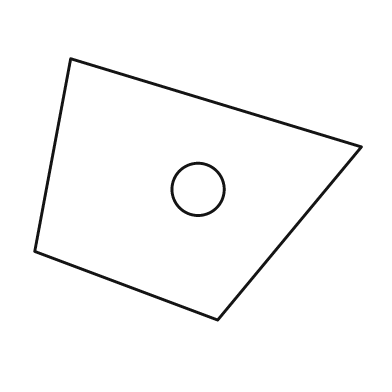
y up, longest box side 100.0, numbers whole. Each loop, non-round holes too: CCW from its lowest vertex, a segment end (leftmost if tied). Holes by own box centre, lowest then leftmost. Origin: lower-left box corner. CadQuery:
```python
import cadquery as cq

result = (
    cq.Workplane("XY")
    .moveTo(56.0, 0.0)
    .lineTo(100.0, 53.0)
    .lineTo(11.0, 80.0)
    .lineTo(0.0, 21.0)
    .close()
    .moveTo(50.0, 40.0)
    .circle(8.0)
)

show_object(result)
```